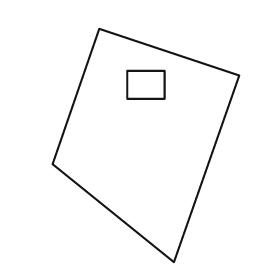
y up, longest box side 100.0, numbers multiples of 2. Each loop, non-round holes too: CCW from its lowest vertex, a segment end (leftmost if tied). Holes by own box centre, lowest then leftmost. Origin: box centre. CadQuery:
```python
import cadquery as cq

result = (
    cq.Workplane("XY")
    .moveTo(12.0, -50.0)
    .lineTo(40.0, 30.0)
    .lineTo(-20.0, 50.0)
    .lineTo(-40.0, -8.0)
    .close()
    .moveTo(-8.0, 20.0)
    .lineTo(8.0, 20.0)
    .lineTo(8.0, 32.0)
    .lineTo(-8.0, 32.0)
    .close()
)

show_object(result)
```